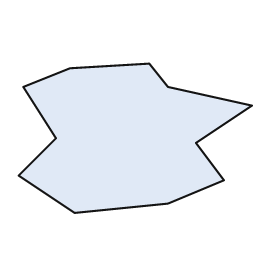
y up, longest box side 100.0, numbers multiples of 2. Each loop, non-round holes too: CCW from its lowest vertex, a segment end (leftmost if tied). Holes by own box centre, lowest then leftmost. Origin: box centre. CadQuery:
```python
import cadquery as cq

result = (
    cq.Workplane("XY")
    .moveTo(-26.0, -32.0)
    .lineTo(14.0, -28.0)
    .lineTo(38.0, -18.0)
    .lineTo(26.0, -2.0)
    .lineTo(50.0, 14.0)
    .lineTo(14.0, 22.0)
    .lineTo(6.0, 32.0)
    .lineTo(-28.0, 30.0)
    .lineTo(-48.0, 22.0)
    .lineTo(-34.0, 0.0)
    .lineTo(-50.0, -16.0)
    .close()
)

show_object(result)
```